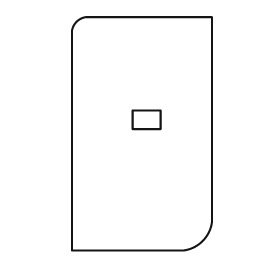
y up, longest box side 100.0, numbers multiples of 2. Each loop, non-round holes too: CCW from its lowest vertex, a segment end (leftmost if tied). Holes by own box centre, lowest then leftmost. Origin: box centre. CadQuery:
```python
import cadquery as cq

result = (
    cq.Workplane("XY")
    .moveTo(-30.0, -50.0)
    .lineTo(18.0, -50.0)
    .threePointArc((26.0, -46.0), (30.0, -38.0))
    .lineTo(30.0, 50.0)
    .lineTo(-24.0, 50.0)
    .threePointArc((-28.0, 48.0), (-30.0, 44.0))
    .close()
    .moveTo(-4.0, 2.0)
    .lineTo(8.0, 2.0)
    .lineTo(8.0, 10.0)
    .lineTo(-4.0, 10.0)
    .close()
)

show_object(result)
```